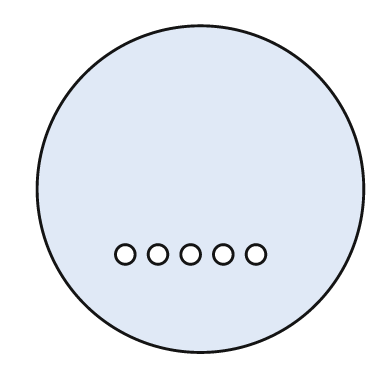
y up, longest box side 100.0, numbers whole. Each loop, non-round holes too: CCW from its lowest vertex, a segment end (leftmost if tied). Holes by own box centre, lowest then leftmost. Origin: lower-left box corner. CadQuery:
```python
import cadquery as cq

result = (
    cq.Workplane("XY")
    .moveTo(50.0, 50.0)
    .circle(50.0)
    .moveTo(27.0, 30.0)
    .circle(3.0)
    .moveTo(37.0, 30.0)
    .circle(3.0)
    .moveTo(47.0, 30.0)
    .circle(3.0)
    .moveTo(57.0, 30.0)
    .circle(3.0)
    .moveTo(67.0, 30.0)
    .circle(3.0)
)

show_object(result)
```